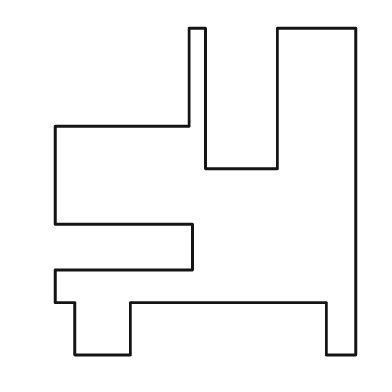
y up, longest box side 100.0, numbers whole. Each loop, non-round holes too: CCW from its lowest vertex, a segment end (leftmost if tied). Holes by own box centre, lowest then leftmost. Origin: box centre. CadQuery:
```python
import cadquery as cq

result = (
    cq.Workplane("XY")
    .moveTo(-40.0, -50.0)
    .lineTo(-23.0, -50.0)
    .lineTo(-23.0, -34.0)
    .lineTo(37.0, -34.0)
    .lineTo(37.0, -50.0)
    .lineTo(46.0, -50.0)
    .lineTo(46.0, 50.0)
    .lineTo(22.0, 50.0)
    .lineTo(22.0, 7.0)
    .lineTo(0.0, 7.0)
    .lineTo(0.0, 50.0)
    .lineTo(-5.0, 50.0)
    .lineTo(-5.0, 20.0)
    .lineTo(-46.0, 20.0)
    .lineTo(-46.0, -10.0)
    .lineTo(-4.0, -10.0)
    .lineTo(-4.0, -24.0)
    .lineTo(-46.0, -24.0)
    .lineTo(-46.0, -34.0)
    .lineTo(-40.0, -34.0)
    .close()
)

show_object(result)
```